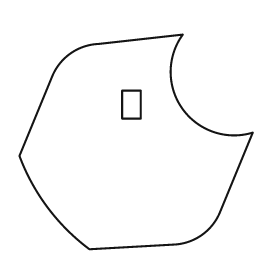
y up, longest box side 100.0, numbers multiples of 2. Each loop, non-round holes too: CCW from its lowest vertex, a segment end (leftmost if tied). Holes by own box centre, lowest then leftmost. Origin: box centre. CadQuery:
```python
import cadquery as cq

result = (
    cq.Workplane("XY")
    .moveTo(-20.0, -46.0)
    .lineTo(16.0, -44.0)
    .threePointArc((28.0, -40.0), (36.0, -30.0))
    .lineTo(50.0, 4.0)
    .threePointArc((20.0, 14.0), (20.0, 46.0))
    .lineTo(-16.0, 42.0)
    .threePointArc((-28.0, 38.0), (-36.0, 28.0))
    .lineTo(-50.0, -6.0)
    .threePointArc((-38.0, -28.0), (-20.0, -46.0))
    .close()
    .moveTo(-6.0, 10.0)
    .lineTo(2.0, 10.0)
    .lineTo(2.0, 22.0)
    .lineTo(-6.0, 22.0)
    .close()
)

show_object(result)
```